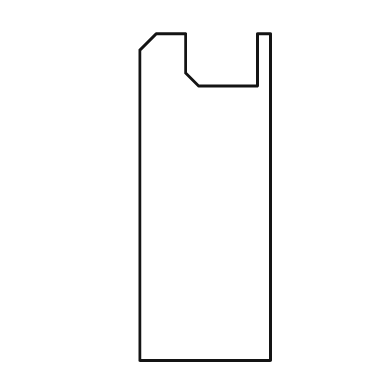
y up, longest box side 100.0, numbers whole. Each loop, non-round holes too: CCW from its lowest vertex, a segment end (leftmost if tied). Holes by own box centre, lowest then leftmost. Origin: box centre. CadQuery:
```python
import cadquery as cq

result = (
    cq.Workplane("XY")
    .moveTo(-20.0, -50.0)
    .lineTo(20.0, -50.0)
    .lineTo(20.0, 50.0)
    .lineTo(16.0, 50.0)
    .lineTo(16.0, 34.0)
    .lineTo(-2.0, 34.0)
    .lineTo(-6.0, 38.0)
    .lineTo(-6.0, 50.0)
    .lineTo(-15.0, 50.0)
    .lineTo(-20.0, 45.0)
    .close()
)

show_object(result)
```